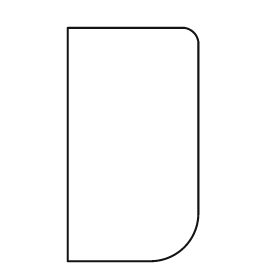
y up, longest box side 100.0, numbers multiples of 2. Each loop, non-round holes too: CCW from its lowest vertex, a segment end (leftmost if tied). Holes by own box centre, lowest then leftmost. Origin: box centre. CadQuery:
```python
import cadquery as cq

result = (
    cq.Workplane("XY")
    .moveTo(-28.0, -50.0)
    .lineTo(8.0, -50.0)
    .threePointArc((22.0, -44.0), (28.0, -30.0))
    .lineTo(28.0, 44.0)
    .threePointArc((26.0, 48.0), (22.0, 50.0))
    .lineTo(-28.0, 50.0)
    .close()
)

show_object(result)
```